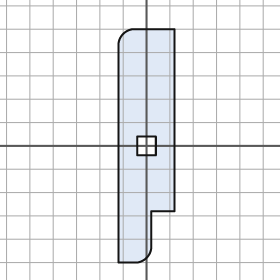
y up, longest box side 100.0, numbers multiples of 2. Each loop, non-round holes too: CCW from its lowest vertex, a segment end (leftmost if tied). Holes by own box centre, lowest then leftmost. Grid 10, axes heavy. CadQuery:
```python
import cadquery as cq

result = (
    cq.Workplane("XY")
    .moveTo(-12.0, -50.0)
    .lineTo(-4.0, -50.0)
    .threePointArc((0.0, -48.0), (2.0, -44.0))
    .lineTo(2.0, -28.0)
    .lineTo(12.0, -28.0)
    .lineTo(12.0, 50.0)
    .lineTo(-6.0, 50.0)
    .threePointArc((-10.0, 48.0), (-12.0, 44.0))
    .close()
    .moveTo(-4.0, -4.0)
    .lineTo(4.0, -4.0)
    .lineTo(4.0, 4.0)
    .lineTo(-4.0, 4.0)
    .close()
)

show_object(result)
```